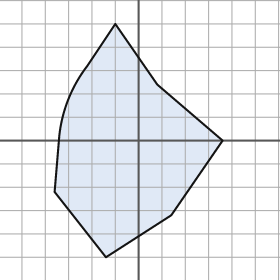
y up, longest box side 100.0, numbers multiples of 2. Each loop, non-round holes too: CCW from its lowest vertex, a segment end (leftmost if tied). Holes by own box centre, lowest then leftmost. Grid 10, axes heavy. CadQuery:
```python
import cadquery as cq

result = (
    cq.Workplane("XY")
    .moveTo(-14.0, -50.0)
    .lineTo(14.0, -32.0)
    .lineTo(36.0, 0.0)
    .lineTo(8.0, 24.0)
    .lineTo(-10.0, 50.0)
    .lineTo(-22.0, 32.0)
    .threePointArc((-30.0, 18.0), (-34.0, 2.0))
    .lineTo(-36.0, -22.0)
    .close()
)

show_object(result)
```